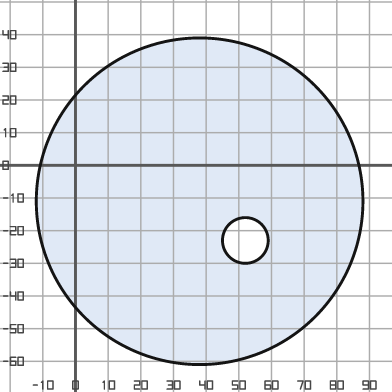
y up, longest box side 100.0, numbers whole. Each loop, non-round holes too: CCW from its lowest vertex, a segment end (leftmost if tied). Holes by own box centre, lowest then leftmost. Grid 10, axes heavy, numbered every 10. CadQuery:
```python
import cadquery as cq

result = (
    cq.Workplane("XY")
    .moveTo(38.0, -11.0)
    .circle(50.0)
    .moveTo(52.0, -23.0)
    .circle(7.0)
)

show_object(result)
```